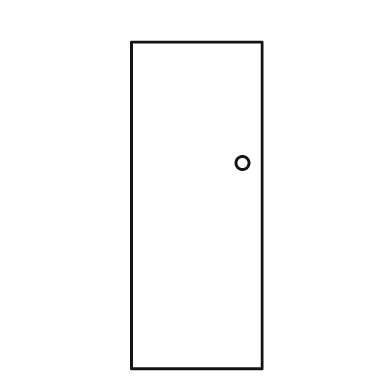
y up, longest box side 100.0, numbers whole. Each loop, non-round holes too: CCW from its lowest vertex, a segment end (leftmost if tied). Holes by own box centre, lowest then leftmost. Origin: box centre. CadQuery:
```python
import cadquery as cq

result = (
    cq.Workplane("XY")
    .moveTo(-20.0, -50.0)
    .lineTo(20.0, -50.0)
    .lineTo(20.0, 50.0)
    .lineTo(-20.0, 50.0)
    .close()
    .moveTo(14.0, 13.0)
    .circle(2.0)
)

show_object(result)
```